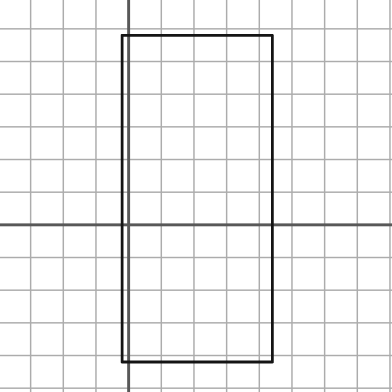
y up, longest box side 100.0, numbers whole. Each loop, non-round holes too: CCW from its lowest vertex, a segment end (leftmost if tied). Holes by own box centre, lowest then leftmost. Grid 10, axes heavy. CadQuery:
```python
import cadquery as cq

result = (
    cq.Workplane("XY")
    .moveTo(-2.0, -42.0)
    .lineTo(44.0, -42.0)
    .lineTo(44.0, 58.0)
    .lineTo(-2.0, 58.0)
    .close()
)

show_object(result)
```